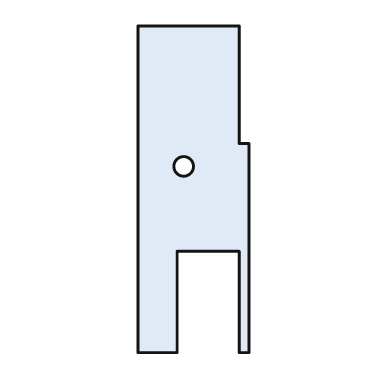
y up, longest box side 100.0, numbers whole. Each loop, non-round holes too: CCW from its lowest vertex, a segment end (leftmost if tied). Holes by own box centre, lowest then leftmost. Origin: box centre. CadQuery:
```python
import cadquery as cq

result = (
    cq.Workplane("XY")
    .moveTo(-17.0, -50.0)
    .lineTo(-5.0, -50.0)
    .lineTo(-5.0, -19.0)
    .lineTo(14.0, -19.0)
    .lineTo(14.0, -50.0)
    .lineTo(17.0, -50.0)
    .lineTo(17.0, 14.0)
    .lineTo(14.0, 14.0)
    .lineTo(14.0, 50.0)
    .lineTo(-17.0, 50.0)
    .close()
    .moveTo(-3.0, 7.0)
    .circle(3.0)
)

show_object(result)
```